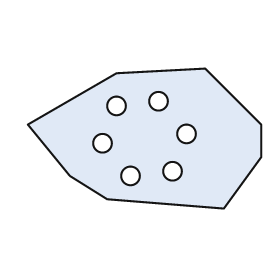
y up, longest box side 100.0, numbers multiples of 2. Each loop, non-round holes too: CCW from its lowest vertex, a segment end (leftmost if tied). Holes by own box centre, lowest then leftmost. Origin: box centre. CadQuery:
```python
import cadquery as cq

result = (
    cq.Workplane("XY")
    .moveTo(34.0, -30.0)
    .lineTo(50.0, -8.0)
    .lineTo(50.0, 6.0)
    .lineTo(26.0, 30.0)
    .lineTo(-12.0, 28.0)
    .lineTo(-50.0, 6.0)
    .lineTo(-32.0, -16.0)
    .lineTo(-16.0, -26.0)
    .close()
    .moveTo(-6.0, -16.0)
    .circle(4.0)
    .moveTo(12.0, -14.0)
    .circle(4.0)
    .moveTo(-18.0, -2.0)
    .circle(4.0)
    .moveTo(18.0, 2.0)
    .circle(4.0)
    .moveTo(-12.0, 14.0)
    .circle(4.0)
    .moveTo(6.0, 16.0)
    .circle(4.0)
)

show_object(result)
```